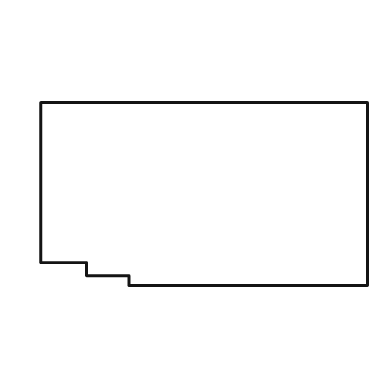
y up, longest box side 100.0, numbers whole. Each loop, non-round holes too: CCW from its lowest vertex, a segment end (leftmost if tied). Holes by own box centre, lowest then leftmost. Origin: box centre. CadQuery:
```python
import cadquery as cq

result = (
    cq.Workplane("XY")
    .moveTo(-23.0, -28.0)
    .lineTo(50.0, -28.0)
    .lineTo(50.0, 28.0)
    .lineTo(-50.0, 28.0)
    .lineTo(-50.0, -21.0)
    .lineTo(-36.0, -21.0)
    .lineTo(-36.0, -25.0)
    .lineTo(-23.0, -25.0)
    .close()
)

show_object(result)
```